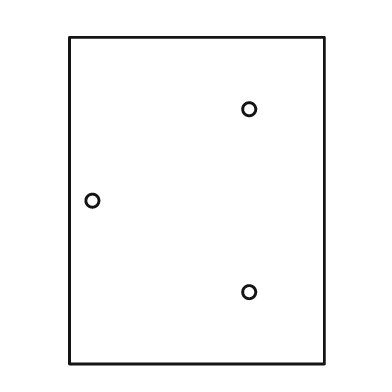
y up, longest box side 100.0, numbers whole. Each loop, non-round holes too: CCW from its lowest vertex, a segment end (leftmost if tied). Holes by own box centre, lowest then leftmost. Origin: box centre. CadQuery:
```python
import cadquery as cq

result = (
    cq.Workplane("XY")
    .moveTo(-39.0, -50.0)
    .lineTo(39.0, -50.0)
    .lineTo(39.0, 50.0)
    .lineTo(-39.0, 50.0)
    .close()
    .moveTo(16.0, -28.0)
    .circle(2.0)
    .moveTo(-32.0, 0.0)
    .circle(2.0)
    .moveTo(16.0, 28.0)
    .circle(2.0)
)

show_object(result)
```